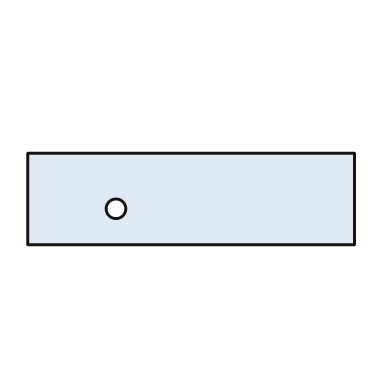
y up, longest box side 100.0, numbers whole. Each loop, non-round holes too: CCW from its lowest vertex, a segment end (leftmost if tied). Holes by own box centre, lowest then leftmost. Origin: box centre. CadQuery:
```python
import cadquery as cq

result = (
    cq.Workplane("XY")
    .moveTo(-50.0, -14.0)
    .lineTo(50.0, -14.0)
    .lineTo(50.0, 14.0)
    .lineTo(-50.0, 14.0)
    .close()
    .moveTo(-23.0, -3.0)
    .circle(3.0)
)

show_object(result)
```